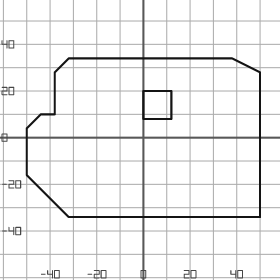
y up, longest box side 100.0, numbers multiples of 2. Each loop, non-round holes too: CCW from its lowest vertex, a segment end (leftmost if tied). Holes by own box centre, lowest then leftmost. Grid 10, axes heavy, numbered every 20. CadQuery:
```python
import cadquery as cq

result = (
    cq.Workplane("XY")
    .moveTo(-32.0, -34.0)
    .lineTo(50.0, -34.0)
    .lineTo(50.0, 28.0)
    .lineTo(38.0, 34.0)
    .lineTo(-32.0, 34.0)
    .lineTo(-38.0, 28.0)
    .lineTo(-38.0, 10.0)
    .lineTo(-44.0, 10.0)
    .lineTo(-50.0, 4.0)
    .lineTo(-50.0, -16.0)
    .close()
    .moveTo(0.0, 8.0)
    .lineTo(12.0, 8.0)
    .lineTo(12.0, 20.0)
    .lineTo(0.0, 20.0)
    .close()
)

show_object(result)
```